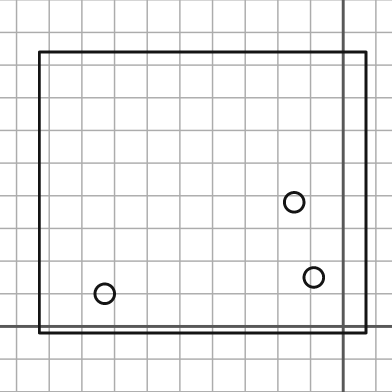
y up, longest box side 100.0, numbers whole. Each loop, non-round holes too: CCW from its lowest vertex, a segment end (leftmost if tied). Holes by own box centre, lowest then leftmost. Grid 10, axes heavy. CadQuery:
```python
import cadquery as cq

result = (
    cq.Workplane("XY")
    .moveTo(-93.0, -2.0)
    .lineTo(7.0, -2.0)
    .lineTo(7.0, 84.0)
    .lineTo(-93.0, 84.0)
    .close()
    .moveTo(-73.0, 10.0)
    .circle(3.0)
    .moveTo(-9.0, 15.0)
    .circle(3.0)
    .moveTo(-15.0, 38.0)
    .circle(3.0)
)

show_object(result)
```